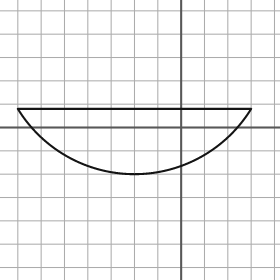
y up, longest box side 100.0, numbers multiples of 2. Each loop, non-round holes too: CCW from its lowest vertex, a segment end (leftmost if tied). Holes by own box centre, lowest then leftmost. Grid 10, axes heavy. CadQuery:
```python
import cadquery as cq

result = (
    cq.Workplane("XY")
    .moveTo(-70.0, 8.0)
    .threePointArc((-20.0, -20.0), (30.0, 8.0))
    .close()
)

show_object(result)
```